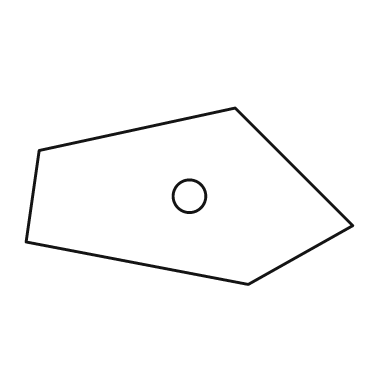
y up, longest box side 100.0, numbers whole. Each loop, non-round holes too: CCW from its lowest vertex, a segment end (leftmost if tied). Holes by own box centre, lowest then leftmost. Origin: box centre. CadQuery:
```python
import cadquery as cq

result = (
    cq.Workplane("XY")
    .moveTo(18.0, -27.0)
    .lineTo(50.0, -9.0)
    .lineTo(14.0, 27.0)
    .lineTo(-46.0, 14.0)
    .lineTo(-50.0, -14.0)
    .close()
    .moveTo(0.0, 0.0)
    .circle(5.0)
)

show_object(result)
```